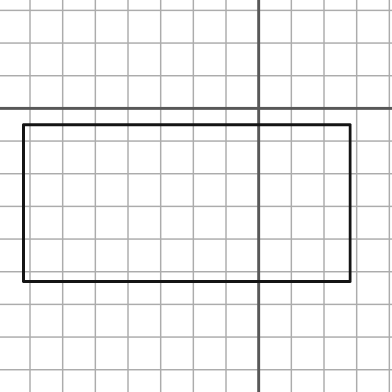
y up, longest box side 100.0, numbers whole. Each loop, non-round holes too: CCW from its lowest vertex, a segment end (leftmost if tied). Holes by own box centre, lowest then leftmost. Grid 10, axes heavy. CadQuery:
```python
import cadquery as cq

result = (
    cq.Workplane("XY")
    .moveTo(-72.0, -53.0)
    .lineTo(28.0, -53.0)
    .lineTo(28.0, -5.0)
    .lineTo(-72.0, -5.0)
    .close()
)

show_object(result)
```